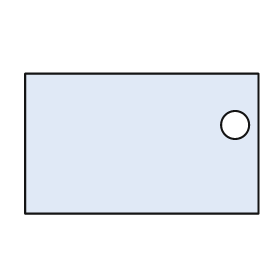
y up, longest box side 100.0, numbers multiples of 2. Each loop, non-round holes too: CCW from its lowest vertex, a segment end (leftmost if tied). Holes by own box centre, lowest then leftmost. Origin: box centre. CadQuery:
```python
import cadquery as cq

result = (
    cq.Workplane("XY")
    .moveTo(-50.0, -30.0)
    .lineTo(50.0, -30.0)
    .lineTo(50.0, 30.0)
    .lineTo(-50.0, 30.0)
    .close()
    .moveTo(40.0, 8.0)
    .circle(6.0)
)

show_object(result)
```